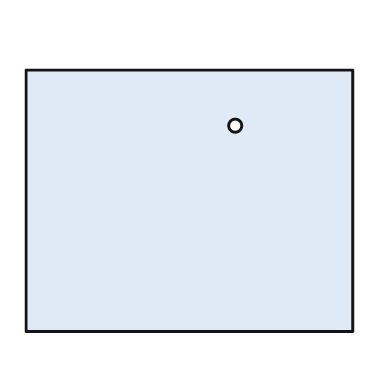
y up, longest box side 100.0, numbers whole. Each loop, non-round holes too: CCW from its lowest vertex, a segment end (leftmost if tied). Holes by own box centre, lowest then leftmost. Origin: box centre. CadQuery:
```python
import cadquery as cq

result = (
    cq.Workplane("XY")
    .moveTo(-50.0, -40.0)
    .lineTo(50.0, -40.0)
    .lineTo(50.0, 40.0)
    .lineTo(-50.0, 40.0)
    .close()
    .moveTo(14.0, 23.0)
    .circle(2.0)
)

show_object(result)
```